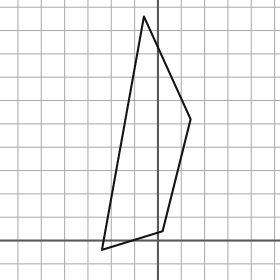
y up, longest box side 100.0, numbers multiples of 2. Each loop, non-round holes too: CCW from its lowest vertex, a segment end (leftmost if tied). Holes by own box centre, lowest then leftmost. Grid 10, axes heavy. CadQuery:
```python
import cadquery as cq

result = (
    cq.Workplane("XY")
    .moveTo(-24.0, -4.0)
    .lineTo(2.0, 4.0)
    .lineTo(14.0, 52.0)
    .lineTo(-6.0, 96.0)
    .close()
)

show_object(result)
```